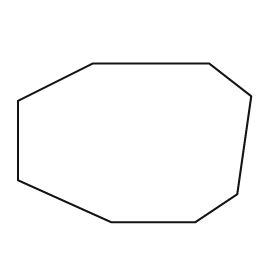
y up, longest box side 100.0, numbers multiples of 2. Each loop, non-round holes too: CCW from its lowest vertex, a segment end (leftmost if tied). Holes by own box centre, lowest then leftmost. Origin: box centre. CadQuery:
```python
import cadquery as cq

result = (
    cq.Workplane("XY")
    .moveTo(-10.0, -34.0)
    .lineTo(26.0, -34.0)
    .lineTo(44.0, -22.0)
    .lineTo(50.0, 20.0)
    .lineTo(32.0, 34.0)
    .lineTo(-18.0, 34.0)
    .lineTo(-50.0, 18.0)
    .lineTo(-50.0, -16.0)
    .close()
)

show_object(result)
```